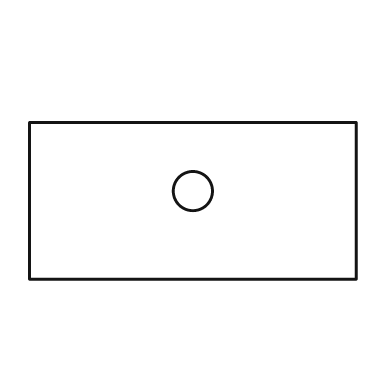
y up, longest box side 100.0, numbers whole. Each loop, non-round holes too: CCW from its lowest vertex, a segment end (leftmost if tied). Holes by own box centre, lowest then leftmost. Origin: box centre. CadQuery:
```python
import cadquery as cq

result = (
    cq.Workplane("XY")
    .moveTo(-50.0, -24.0)
    .lineTo(50.0, -24.0)
    .lineTo(50.0, 24.0)
    .lineTo(-50.0, 24.0)
    .close()
    .moveTo(0.0, 3.0)
    .circle(6.0)
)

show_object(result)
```